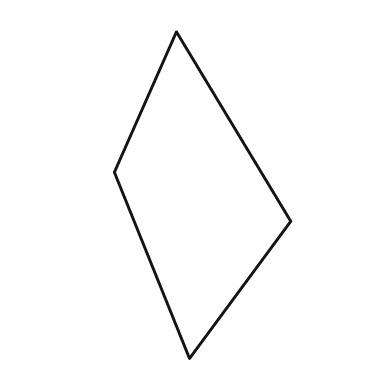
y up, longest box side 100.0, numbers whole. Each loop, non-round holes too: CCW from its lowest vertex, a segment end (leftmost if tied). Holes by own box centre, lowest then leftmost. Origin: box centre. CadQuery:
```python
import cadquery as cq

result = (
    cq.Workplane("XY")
    .moveTo(-4.0, -50.0)
    .lineTo(27.0, -8.0)
    .lineTo(-8.0, 50.0)
    .lineTo(-27.0, 7.0)
    .close()
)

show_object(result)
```